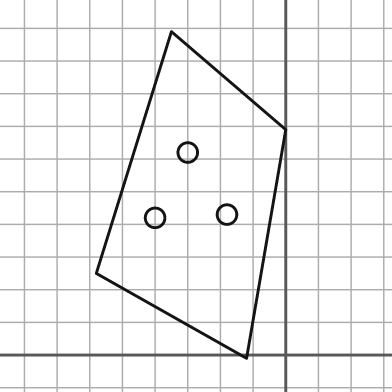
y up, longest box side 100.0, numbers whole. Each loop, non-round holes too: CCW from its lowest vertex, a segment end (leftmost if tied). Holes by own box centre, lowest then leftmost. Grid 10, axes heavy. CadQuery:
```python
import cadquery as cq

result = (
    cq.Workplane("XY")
    .moveTo(-12.0, -1.0)
    .lineTo(0.0, 69.0)
    .lineTo(-35.0, 99.0)
    .lineTo(-58.0, 25.0)
    .close()
    .moveTo(-40.0, 42.0)
    .circle(3.0)
    .moveTo(-18.0, 43.0)
    .circle(3.0)
    .moveTo(-30.0, 62.0)
    .circle(3.0)
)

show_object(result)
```